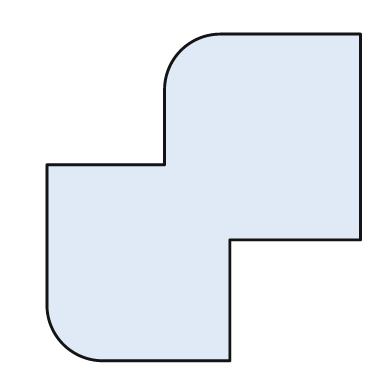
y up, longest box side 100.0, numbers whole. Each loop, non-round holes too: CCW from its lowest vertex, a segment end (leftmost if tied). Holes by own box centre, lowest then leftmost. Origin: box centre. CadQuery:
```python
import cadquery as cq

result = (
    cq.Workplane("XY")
    .moveTo(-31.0, -50.0)
    .lineTo(8.0, -50.0)
    .lineTo(8.0, -13.0)
    .lineTo(48.0, -13.0)
    .lineTo(48.0, 50.0)
    .lineTo(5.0, 50.0)
    .threePointArc((-7.0, 45.0), (-12.0, 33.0))
    .lineTo(-12.0, 10.0)
    .lineTo(-48.0, 10.0)
    .lineTo(-48.0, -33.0)
    .threePointArc((-43.0, -45.0), (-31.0, -50.0))
    .close()
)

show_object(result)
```